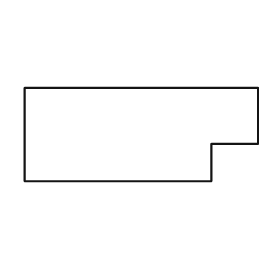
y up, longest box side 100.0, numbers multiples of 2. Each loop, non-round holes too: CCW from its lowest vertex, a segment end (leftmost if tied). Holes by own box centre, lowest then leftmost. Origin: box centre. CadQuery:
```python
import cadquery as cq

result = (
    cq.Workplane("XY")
    .moveTo(-50.0, -20.0)
    .lineTo(30.0, -20.0)
    .lineTo(30.0, -4.0)
    .lineTo(50.0, -4.0)
    .lineTo(50.0, 20.0)
    .lineTo(-50.0, 20.0)
    .close()
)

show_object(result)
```